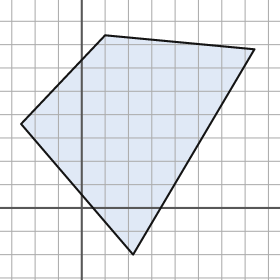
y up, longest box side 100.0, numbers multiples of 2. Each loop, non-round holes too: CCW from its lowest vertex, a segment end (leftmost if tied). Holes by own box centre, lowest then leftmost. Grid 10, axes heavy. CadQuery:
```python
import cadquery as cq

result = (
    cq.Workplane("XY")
    .moveTo(22.0, -20.0)
    .lineTo(74.0, 68.0)
    .lineTo(10.0, 74.0)
    .lineTo(-26.0, 36.0)
    .close()
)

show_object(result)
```